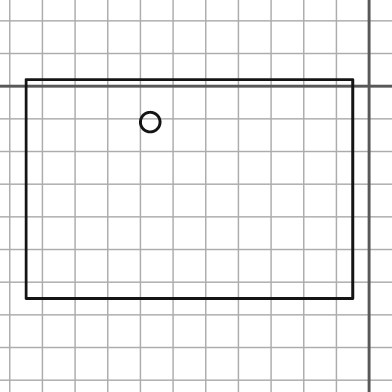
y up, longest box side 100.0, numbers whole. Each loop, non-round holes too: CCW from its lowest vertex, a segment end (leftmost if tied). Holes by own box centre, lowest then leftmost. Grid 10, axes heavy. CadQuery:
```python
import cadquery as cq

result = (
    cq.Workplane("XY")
    .moveTo(-105.0, -65.0)
    .lineTo(-5.0, -65.0)
    .lineTo(-5.0, 2.0)
    .lineTo(-105.0, 2.0)
    .close()
    .moveTo(-67.0, -11.0)
    .circle(3.0)
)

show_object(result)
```